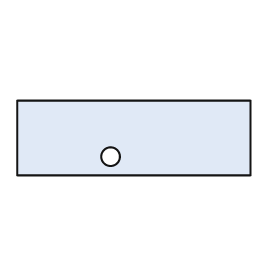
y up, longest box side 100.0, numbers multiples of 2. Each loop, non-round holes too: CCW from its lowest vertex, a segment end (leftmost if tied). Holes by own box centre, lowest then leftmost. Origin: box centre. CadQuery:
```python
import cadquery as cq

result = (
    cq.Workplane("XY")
    .moveTo(-50.0, -16.0)
    .lineTo(50.0, -16.0)
    .lineTo(50.0, 16.0)
    .lineTo(-50.0, 16.0)
    .close()
    .moveTo(-10.0, -8.0)
    .circle(4.0)
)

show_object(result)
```